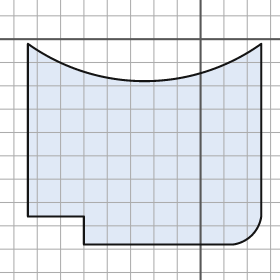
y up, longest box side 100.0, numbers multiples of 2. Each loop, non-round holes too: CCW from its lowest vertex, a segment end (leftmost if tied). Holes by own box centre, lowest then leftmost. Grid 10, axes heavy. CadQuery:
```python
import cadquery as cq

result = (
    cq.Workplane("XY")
    .moveTo(-50.0, -88.0)
    .lineTo(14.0, -88.0)
    .threePointArc((22.0, -84.0), (26.0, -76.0))
    .lineTo(26.0, -2.0)
    .threePointArc((-24.0, -18.0), (-74.0, -2.0))
    .lineTo(-74.0, -76.0)
    .lineTo(-50.0, -76.0)
    .close()
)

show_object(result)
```